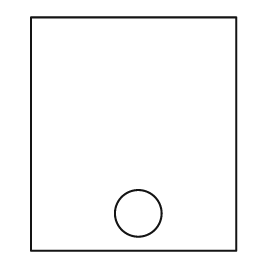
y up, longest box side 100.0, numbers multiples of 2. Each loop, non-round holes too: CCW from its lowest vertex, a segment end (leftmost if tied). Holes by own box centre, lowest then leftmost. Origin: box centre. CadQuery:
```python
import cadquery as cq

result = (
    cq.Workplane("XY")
    .moveTo(-44.0, -50.0)
    .lineTo(44.0, -50.0)
    .lineTo(44.0, 50.0)
    .lineTo(-44.0, 50.0)
    .close()
    .moveTo(2.0, -34.0)
    .circle(10.0)
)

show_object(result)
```